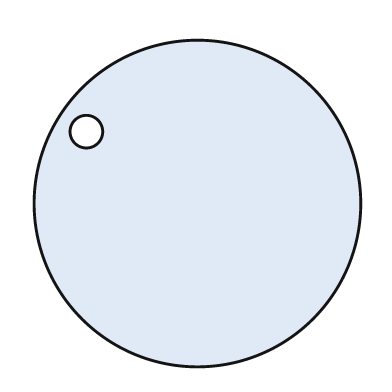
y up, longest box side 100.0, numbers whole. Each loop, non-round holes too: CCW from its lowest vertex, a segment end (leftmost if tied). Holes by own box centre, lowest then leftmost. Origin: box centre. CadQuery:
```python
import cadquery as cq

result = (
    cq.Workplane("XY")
    .moveTo(0.0, 0.0)
    .circle(50.0)
    .moveTo(-34.0, 22.0)
    .circle(5.0)
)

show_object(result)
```